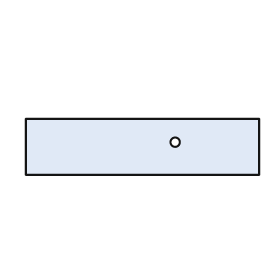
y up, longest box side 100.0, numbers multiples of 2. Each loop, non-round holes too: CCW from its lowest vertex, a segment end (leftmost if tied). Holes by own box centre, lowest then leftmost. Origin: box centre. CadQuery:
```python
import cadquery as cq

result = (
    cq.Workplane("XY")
    .moveTo(-50.0, -12.0)
    .lineTo(50.0, -12.0)
    .lineTo(50.0, 12.0)
    .lineTo(-50.0, 12.0)
    .close()
    .moveTo(14.0, 2.0)
    .circle(2.0)
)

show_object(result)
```